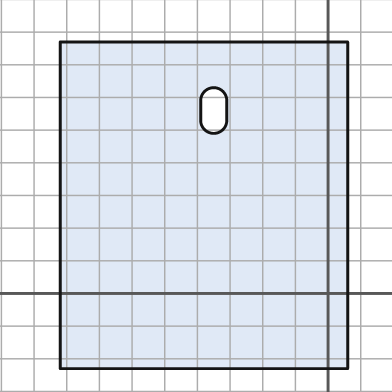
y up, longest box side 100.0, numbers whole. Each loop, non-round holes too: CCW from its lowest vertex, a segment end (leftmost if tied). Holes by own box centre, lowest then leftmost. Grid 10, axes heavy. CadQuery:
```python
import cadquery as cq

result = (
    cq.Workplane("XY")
    .moveTo(-82.0, -23.0)
    .lineTo(6.0, -23.0)
    .lineTo(6.0, 77.0)
    .lineTo(-82.0, 77.0)
    .close()
    .moveTo(-39.0, 53.0)
    .threePointArc((-35.0, 49.0), (-31.0, 53.0))
    .lineTo(-31.0, 59.0)
    .threePointArc((-35.0, 63.0), (-39.0, 59.0))
    .close()
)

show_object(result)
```